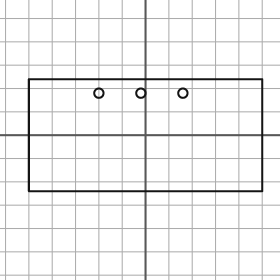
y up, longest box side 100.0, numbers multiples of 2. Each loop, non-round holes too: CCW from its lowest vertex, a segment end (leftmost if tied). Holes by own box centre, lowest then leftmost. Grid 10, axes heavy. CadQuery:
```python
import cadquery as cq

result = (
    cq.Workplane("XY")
    .moveTo(-50.0, -24.0)
    .lineTo(50.0, -24.0)
    .lineTo(50.0, 24.0)
    .lineTo(-50.0, 24.0)
    .close()
    .moveTo(-20.0, 18.0)
    .circle(2.0)
    .moveTo(-2.0, 18.0)
    .circle(2.0)
    .moveTo(16.0, 18.0)
    .circle(2.0)
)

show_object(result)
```